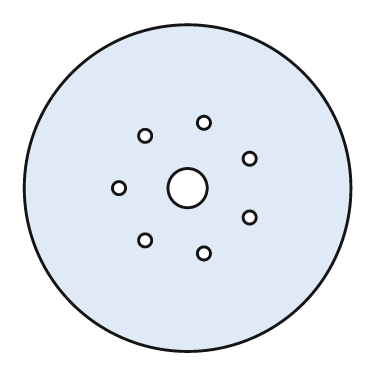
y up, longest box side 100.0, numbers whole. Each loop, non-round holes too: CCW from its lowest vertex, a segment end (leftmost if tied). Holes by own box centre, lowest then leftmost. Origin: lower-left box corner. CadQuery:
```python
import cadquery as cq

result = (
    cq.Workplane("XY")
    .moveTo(50.0, 50.0)
    .circle(50.0)
    .moveTo(55.0, 30.0)
    .circle(2.0)
    .moveTo(37.0, 34.0)
    .circle(2.0)
    .moveTo(69.0, 41.0)
    .circle(2.0)
    .moveTo(29.0, 50.0)
    .circle(2.0)
    .moveTo(50.0, 50.0)
    .circle(6.0)
    .moveTo(69.0, 59.0)
    .circle(2.0)
    .moveTo(37.0, 66.0)
    .circle(2.0)
    .moveTo(55.0, 70.0)
    .circle(2.0)
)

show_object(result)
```